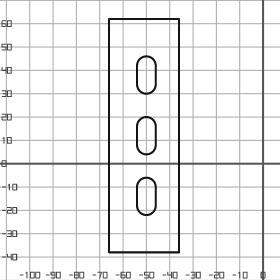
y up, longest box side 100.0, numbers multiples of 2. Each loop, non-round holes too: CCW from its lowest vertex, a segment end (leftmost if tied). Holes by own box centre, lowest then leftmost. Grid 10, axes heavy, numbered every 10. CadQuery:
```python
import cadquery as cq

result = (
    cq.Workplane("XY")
    .moveTo(-66.0, -38.0)
    .lineTo(-36.0, -38.0)
    .lineTo(-36.0, 62.0)
    .lineTo(-66.0, 62.0)
    .close()
    .moveTo(-54.0, -18.0)
    .threePointArc((-50.0, -22.0), (-46.0, -18.0))
    .lineTo(-46.0, -10.0)
    .threePointArc((-50.0, -6.0), (-54.0, -10.0))
    .close()
    .moveTo(-54.0, 8.0)
    .threePointArc((-50.0, 4.0), (-46.0, 8.0))
    .lineTo(-46.0, 16.0)
    .threePointArc((-50.0, 20.0), (-54.0, 16.0))
    .close()
    .moveTo(-54.0, 34.0)
    .threePointArc((-50.0, 30.0), (-46.0, 34.0))
    .lineTo(-46.0, 42.0)
    .threePointArc((-50.0, 46.0), (-54.0, 42.0))
    .close()
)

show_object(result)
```